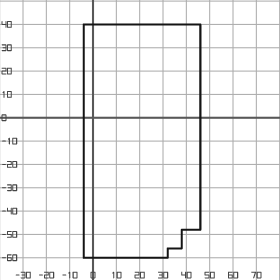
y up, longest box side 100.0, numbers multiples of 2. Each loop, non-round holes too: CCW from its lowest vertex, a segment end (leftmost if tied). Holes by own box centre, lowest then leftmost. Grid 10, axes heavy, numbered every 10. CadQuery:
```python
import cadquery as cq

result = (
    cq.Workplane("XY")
    .moveTo(-4.0, -60.0)
    .lineTo(32.0, -60.0)
    .lineTo(32.0, -56.0)
    .lineTo(38.0, -56.0)
    .lineTo(38.0, -48.0)
    .lineTo(46.0, -48.0)
    .lineTo(46.0, 40.0)
    .lineTo(-4.0, 40.0)
    .close()
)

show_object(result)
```